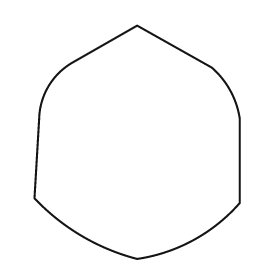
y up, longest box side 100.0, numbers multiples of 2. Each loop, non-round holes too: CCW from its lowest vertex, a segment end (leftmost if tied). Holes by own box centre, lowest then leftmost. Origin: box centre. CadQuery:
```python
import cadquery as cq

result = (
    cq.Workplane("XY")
    .moveTo(0.0, -50.0)
    .threePointArc((24.0, -42.0), (44.0, -26.0))
    .lineTo(44.0, 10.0)
    .threePointArc((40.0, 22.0), (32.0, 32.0))
    .lineTo(0.0, 50.0)
    .lineTo(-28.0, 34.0)
    .threePointArc((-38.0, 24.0), (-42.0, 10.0))
    .lineTo(-44.0, -24.0)
    .threePointArc((-24.0, -40.0), (0.0, -50.0))
    .close()
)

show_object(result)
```